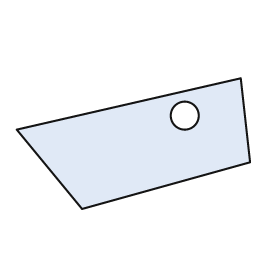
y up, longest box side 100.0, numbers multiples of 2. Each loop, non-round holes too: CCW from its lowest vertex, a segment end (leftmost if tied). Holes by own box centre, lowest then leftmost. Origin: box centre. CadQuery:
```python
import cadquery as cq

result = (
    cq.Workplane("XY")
    .moveTo(-22.0, -28.0)
    .lineTo(50.0, -8.0)
    .lineTo(46.0, 28.0)
    .lineTo(-50.0, 6.0)
    .close()
    .moveTo(22.0, 12.0)
    .circle(6.0)
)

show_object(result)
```